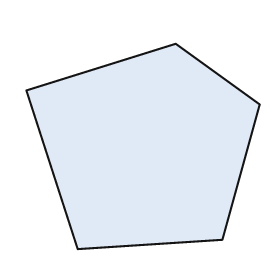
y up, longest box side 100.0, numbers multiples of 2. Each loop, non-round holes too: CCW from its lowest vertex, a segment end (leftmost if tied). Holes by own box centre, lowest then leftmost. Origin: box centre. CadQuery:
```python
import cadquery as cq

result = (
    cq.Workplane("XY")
    .moveTo(-28.0, -44.0)
    .lineTo(34.0, -40.0)
    .lineTo(50.0, 18.0)
    .lineTo(14.0, 44.0)
    .lineTo(-50.0, 24.0)
    .close()
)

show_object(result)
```